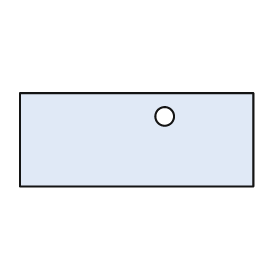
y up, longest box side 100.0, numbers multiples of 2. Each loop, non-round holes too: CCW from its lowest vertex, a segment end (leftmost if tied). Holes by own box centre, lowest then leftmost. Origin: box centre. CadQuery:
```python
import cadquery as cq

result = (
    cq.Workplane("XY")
    .moveTo(-50.0, -20.0)
    .lineTo(50.0, -20.0)
    .lineTo(50.0, 20.0)
    .lineTo(-50.0, 20.0)
    .close()
    .moveTo(12.0, 10.0)
    .circle(4.0)
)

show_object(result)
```